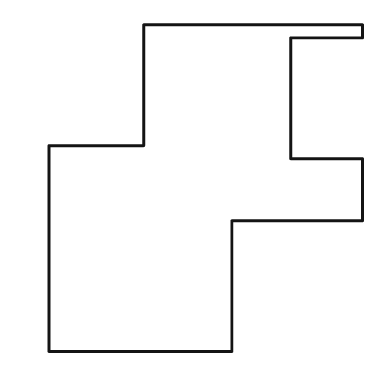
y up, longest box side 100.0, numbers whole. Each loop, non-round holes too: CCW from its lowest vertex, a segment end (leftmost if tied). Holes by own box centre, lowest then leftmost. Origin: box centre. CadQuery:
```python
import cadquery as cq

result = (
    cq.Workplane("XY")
    .moveTo(-48.0, -50.0)
    .lineTo(8.0, -50.0)
    .lineTo(8.0, -10.0)
    .lineTo(48.0, -10.0)
    .lineTo(48.0, 9.0)
    .lineTo(26.0, 9.0)
    .lineTo(26.0, 46.0)
    .lineTo(48.0, 46.0)
    .lineTo(48.0, 50.0)
    .lineTo(-19.0, 50.0)
    .lineTo(-19.0, 13.0)
    .lineTo(-48.0, 13.0)
    .close()
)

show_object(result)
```